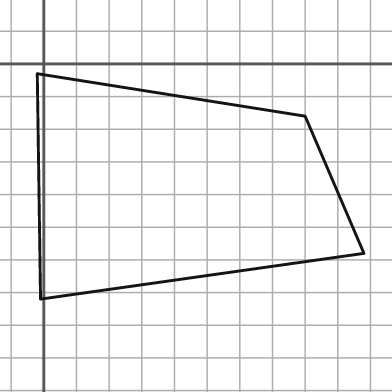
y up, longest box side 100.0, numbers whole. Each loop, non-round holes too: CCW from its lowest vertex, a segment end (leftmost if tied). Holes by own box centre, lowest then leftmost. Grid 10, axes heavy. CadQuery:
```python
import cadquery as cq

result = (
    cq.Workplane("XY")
    .moveTo(-1.0, -72.0)
    .lineTo(98.0, -58.0)
    .lineTo(80.0, -16.0)
    .lineTo(-2.0, -3.0)
    .close()
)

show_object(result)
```